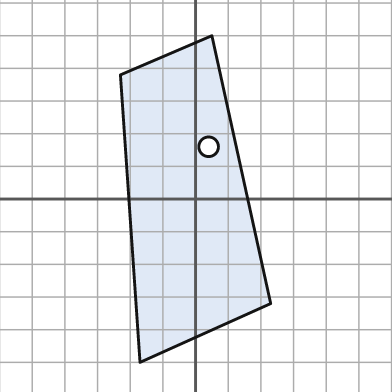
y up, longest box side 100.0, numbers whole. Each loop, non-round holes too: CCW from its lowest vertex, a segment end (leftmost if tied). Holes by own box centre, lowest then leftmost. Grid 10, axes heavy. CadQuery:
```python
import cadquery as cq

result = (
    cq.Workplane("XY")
    .moveTo(-17.0, -50.0)
    .lineTo(23.0, -32.0)
    .lineTo(5.0, 50.0)
    .lineTo(-23.0, 38.0)
    .close()
    .moveTo(4.0, 16.0)
    .circle(3.0)
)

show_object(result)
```